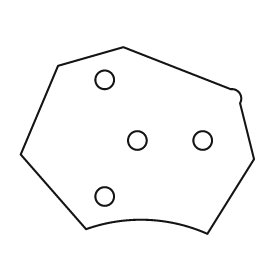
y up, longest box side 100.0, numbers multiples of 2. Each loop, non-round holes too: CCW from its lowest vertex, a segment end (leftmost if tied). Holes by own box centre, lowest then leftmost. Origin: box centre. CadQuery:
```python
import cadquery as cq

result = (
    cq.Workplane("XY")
    .moveTo(30.0, -40.0)
    .lineTo(50.0, -8.0)
    .lineTo(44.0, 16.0)
    .threePointArc((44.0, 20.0), (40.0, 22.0))
    .lineTo(-6.0, 40.0)
    .lineTo(-34.0, 32.0)
    .lineTo(-50.0, -6.0)
    .lineTo(-22.0, -38.0)
    .threePointArc((4.0, -34.0), (30.0, -40.0))
    .close()
    .moveTo(-14.0, -24.0)
    .circle(4.0)
    .moveTo(0.0, 0.0)
    .circle(4.0)
    .moveTo(28.0, 0.0)
    .circle(4.0)
    .moveTo(-14.0, 26.0)
    .circle(4.0)
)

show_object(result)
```